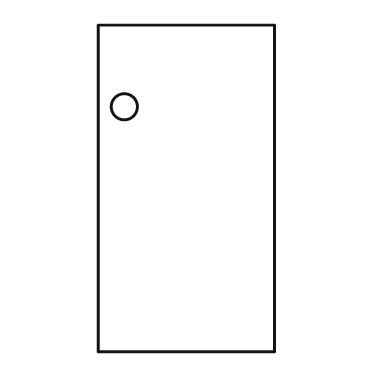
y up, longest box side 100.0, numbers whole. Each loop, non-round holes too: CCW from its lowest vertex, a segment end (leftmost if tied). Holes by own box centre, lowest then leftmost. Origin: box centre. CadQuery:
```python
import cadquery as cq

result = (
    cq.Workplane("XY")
    .moveTo(-27.0, -50.0)
    .lineTo(27.0, -50.0)
    .lineTo(27.0, 50.0)
    .lineTo(-27.0, 50.0)
    .close()
    .moveTo(-19.0, 25.0)
    .circle(4.0)
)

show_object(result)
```